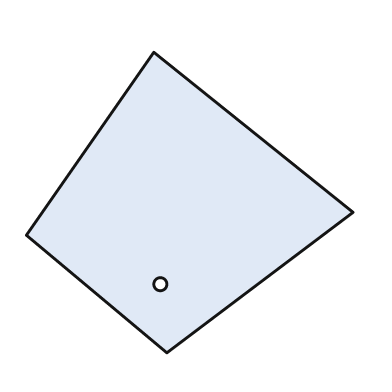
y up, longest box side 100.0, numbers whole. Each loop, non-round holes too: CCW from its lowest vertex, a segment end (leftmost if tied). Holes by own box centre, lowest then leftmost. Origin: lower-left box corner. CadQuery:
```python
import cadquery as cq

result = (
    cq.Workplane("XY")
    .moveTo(43.0, 0.0)
    .lineTo(100.0, 43.0)
    .lineTo(39.0, 92.0)
    .lineTo(0.0, 36.0)
    .close()
    .moveTo(41.0, 21.0)
    .circle(2.0)
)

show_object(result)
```